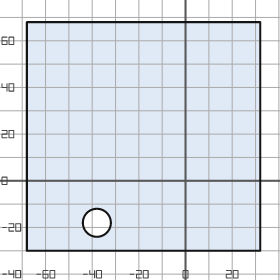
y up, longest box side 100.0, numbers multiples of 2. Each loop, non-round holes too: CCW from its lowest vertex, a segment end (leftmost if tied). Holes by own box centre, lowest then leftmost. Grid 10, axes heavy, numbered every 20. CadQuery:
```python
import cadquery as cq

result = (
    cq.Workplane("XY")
    .moveTo(-68.0, -30.0)
    .lineTo(32.0, -30.0)
    .lineTo(32.0, 68.0)
    .lineTo(-68.0, 68.0)
    .close()
    .moveTo(-38.0, -18.0)
    .circle(6.0)
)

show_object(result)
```